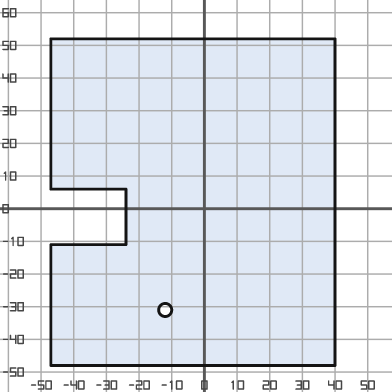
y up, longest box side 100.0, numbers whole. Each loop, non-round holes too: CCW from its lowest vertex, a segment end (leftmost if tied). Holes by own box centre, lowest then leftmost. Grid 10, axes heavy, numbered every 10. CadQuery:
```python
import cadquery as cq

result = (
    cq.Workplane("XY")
    .moveTo(-47.0, -48.0)
    .lineTo(40.0, -48.0)
    .lineTo(40.0, 52.0)
    .lineTo(-47.0, 52.0)
    .lineTo(-47.0, 6.0)
    .lineTo(-24.0, 6.0)
    .lineTo(-24.0, -11.0)
    .lineTo(-47.0, -11.0)
    .close()
    .moveTo(-12.0, -31.0)
    .circle(2.0)
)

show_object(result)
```